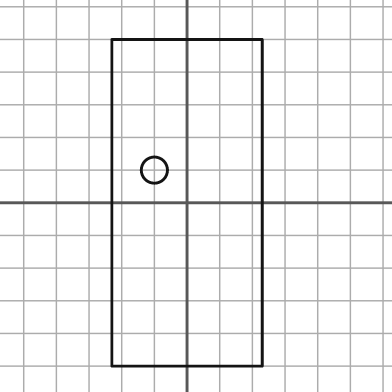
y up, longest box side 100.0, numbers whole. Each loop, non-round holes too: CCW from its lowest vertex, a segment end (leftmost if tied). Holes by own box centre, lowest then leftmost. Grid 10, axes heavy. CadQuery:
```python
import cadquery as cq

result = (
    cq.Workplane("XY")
    .moveTo(-23.0, -50.0)
    .lineTo(23.0, -50.0)
    .lineTo(23.0, 50.0)
    .lineTo(-23.0, 50.0)
    .close()
    .moveTo(-10.0, 10.0)
    .circle(4.0)
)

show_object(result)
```